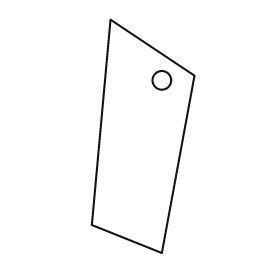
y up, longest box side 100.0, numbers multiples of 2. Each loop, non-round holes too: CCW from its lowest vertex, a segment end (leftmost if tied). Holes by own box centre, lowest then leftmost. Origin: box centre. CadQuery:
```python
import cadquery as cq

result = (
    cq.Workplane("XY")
    .moveTo(8.0, -50.0)
    .lineTo(22.0, 26.0)
    .lineTo(-14.0, 50.0)
    .lineTo(-22.0, -38.0)
    .close()
    .moveTo(8.0, 24.0)
    .circle(4.0)
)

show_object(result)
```